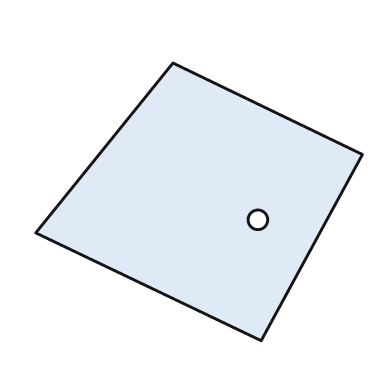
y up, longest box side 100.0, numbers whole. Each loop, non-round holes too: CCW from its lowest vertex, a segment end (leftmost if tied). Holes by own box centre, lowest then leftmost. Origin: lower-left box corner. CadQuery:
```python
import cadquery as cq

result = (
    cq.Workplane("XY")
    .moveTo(69.0, 0.0)
    .lineTo(100.0, 57.0)
    .lineTo(42.0, 85.0)
    .lineTo(0.0, 33.0)
    .close()
    .moveTo(68.0, 37.0)
    .circle(3.0)
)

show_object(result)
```